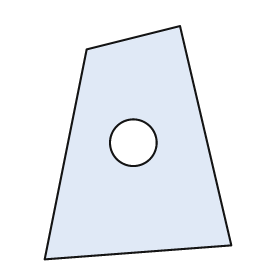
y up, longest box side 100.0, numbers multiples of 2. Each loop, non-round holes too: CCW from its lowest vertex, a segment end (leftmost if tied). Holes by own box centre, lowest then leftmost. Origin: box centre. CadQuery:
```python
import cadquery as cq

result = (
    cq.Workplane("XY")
    .moveTo(-40.0, -50.0)
    .lineTo(40.0, -44.0)
    .lineTo(18.0, 50.0)
    .lineTo(-22.0, 40.0)
    .close()
    .moveTo(-2.0, 0.0)
    .circle(10.0)
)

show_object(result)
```